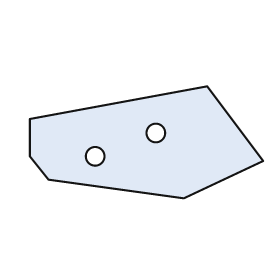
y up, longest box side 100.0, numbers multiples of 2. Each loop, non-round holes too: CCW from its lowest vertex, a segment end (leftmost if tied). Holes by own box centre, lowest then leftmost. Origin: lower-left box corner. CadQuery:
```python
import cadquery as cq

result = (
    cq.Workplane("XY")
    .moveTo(66.0, 0.0)
    .lineTo(100.0, 16.0)
    .lineTo(76.0, 48.0)
    .lineTo(0.0, 34.0)
    .lineTo(0.0, 18.0)
    .lineTo(8.0, 8.0)
    .close()
    .moveTo(28.0, 18.0)
    .circle(4.0)
    .moveTo(54.0, 28.0)
    .circle(4.0)
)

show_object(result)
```